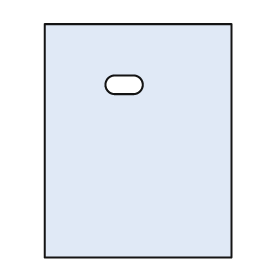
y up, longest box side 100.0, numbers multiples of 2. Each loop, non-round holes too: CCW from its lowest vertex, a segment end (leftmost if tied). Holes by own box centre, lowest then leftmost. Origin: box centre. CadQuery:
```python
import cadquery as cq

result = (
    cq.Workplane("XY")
    .moveTo(-40.0, -50.0)
    .lineTo(40.0, -50.0)
    .lineTo(40.0, 50.0)
    .lineTo(-40.0, 50.0)
    .close()
    .moveTo(-10.0, 20.0)
    .lineTo(-2.0, 20.0)
    .threePointArc((2.0, 24.0), (-2.0, 28.0))
    .lineTo(-10.0, 28.0)
    .threePointArc((-14.0, 24.0), (-10.0, 20.0))
    .close()
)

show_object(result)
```